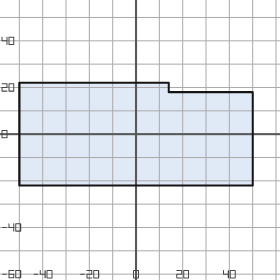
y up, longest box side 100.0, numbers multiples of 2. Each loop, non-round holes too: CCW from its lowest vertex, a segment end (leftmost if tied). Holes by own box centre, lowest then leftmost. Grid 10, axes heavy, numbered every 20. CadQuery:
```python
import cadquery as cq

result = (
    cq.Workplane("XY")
    .moveTo(-50.0, -22.0)
    .lineTo(50.0, -22.0)
    .lineTo(50.0, 18.0)
    .lineTo(14.0, 18.0)
    .lineTo(14.0, 22.0)
    .lineTo(-50.0, 22.0)
    .close()
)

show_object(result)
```